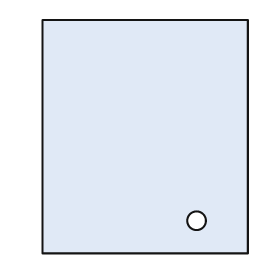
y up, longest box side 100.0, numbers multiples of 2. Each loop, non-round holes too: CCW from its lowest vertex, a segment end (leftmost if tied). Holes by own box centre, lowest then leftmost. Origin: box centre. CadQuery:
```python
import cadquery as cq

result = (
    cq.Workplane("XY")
    .moveTo(-44.0, -50.0)
    .lineTo(44.0, -50.0)
    .lineTo(44.0, 50.0)
    .lineTo(-44.0, 50.0)
    .close()
    .moveTo(22.0, -36.0)
    .circle(4.0)
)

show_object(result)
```